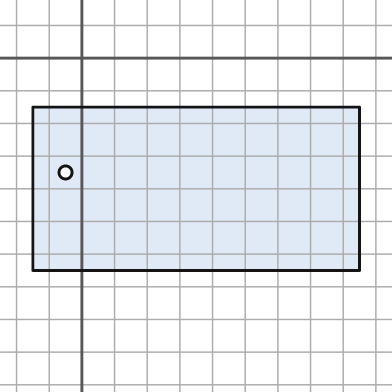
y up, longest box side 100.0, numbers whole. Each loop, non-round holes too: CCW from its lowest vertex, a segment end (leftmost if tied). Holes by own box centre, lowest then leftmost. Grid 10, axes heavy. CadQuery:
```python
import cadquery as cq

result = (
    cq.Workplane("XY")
    .moveTo(-15.0, -65.0)
    .lineTo(85.0, -65.0)
    .lineTo(85.0, -15.0)
    .lineTo(-15.0, -15.0)
    .close()
    .moveTo(-5.0, -35.0)
    .circle(2.0)
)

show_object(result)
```